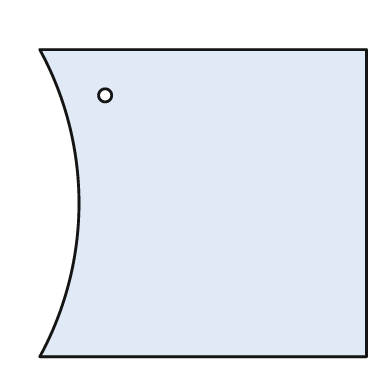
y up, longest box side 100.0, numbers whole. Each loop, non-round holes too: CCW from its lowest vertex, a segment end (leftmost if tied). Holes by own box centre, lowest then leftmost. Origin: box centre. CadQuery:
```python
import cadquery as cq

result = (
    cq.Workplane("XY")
    .moveTo(-50.0, -47.0)
    .lineTo(50.0, -47.0)
    .lineTo(50.0, 47.0)
    .lineTo(-50.0, 47.0)
    .threePointArc((-38.0, 0.0), (-50.0, -47.0))
    .close()
    .moveTo(-30.0, 33.0)
    .circle(2.0)
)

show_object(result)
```